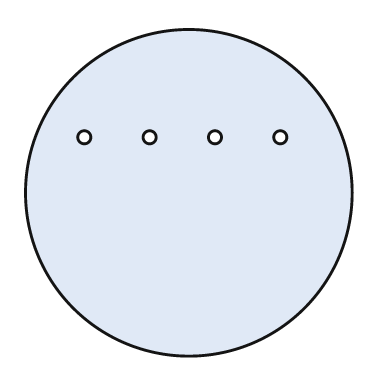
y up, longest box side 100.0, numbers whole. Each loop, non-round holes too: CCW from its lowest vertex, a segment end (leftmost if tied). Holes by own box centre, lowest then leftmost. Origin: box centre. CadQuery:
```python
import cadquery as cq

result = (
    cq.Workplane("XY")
    .moveTo(0.0, 0.0)
    .circle(50.0)
    .moveTo(-32.0, 17.0)
    .circle(2.0)
    .moveTo(-12.0, 17.0)
    .circle(2.0)
    .moveTo(8.0, 17.0)
    .circle(2.0)
    .moveTo(28.0, 17.0)
    .circle(2.0)
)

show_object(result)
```